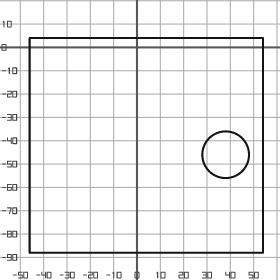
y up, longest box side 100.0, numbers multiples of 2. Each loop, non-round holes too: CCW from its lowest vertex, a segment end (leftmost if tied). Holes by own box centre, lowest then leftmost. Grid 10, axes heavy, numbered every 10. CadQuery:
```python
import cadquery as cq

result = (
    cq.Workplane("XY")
    .moveTo(-46.0, -88.0)
    .lineTo(54.0, -88.0)
    .lineTo(54.0, 4.0)
    .lineTo(-46.0, 4.0)
    .close()
    .moveTo(38.0, -46.0)
    .circle(10.0)
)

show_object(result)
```